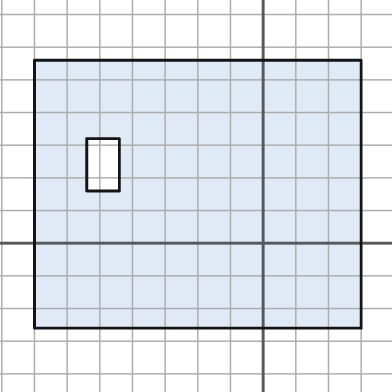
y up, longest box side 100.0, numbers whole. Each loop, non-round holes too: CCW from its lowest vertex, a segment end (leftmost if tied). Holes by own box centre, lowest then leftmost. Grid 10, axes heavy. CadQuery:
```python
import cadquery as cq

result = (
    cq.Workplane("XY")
    .moveTo(-70.0, -26.0)
    .lineTo(30.0, -26.0)
    .lineTo(30.0, 56.0)
    .lineTo(-70.0, 56.0)
    .close()
    .moveTo(-54.0, 16.0)
    .lineTo(-44.0, 16.0)
    .lineTo(-44.0, 32.0)
    .lineTo(-54.0, 32.0)
    .close()
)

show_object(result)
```